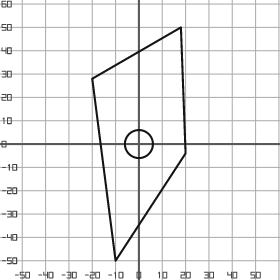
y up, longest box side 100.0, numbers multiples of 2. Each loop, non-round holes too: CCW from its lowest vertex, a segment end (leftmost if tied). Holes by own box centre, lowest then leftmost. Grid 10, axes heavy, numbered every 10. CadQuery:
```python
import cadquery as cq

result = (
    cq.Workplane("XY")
    .moveTo(-10.0, -50.0)
    .lineTo(20.0, -4.0)
    .lineTo(18.0, 50.0)
    .lineTo(-20.0, 28.0)
    .close()
    .moveTo(0.0, 0.0)
    .circle(6.0)
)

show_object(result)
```